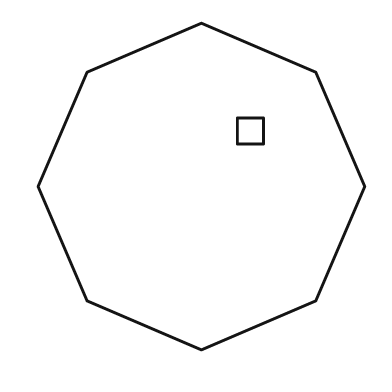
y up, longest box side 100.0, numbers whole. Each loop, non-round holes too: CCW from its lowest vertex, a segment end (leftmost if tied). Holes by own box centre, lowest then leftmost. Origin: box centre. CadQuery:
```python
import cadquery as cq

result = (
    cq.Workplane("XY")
    .moveTo(0.0, -50.0)
    .lineTo(35.0, -35.0)
    .lineTo(50.0, 0.0)
    .lineTo(35.0, 35.0)
    .lineTo(0.0, 50.0)
    .lineTo(-35.0, 35.0)
    .lineTo(-50.0, 0.0)
    .lineTo(-35.0, -35.0)
    .close()
    .moveTo(11.0, 13.0)
    .lineTo(19.0, 13.0)
    .lineTo(19.0, 21.0)
    .lineTo(11.0, 21.0)
    .close()
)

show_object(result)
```